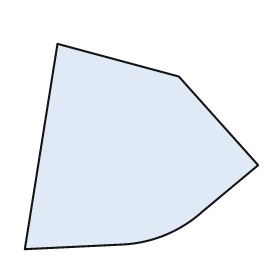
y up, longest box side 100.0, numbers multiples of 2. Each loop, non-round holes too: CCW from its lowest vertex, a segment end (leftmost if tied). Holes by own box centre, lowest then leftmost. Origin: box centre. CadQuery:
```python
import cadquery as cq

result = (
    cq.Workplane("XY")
    .moveTo(-50.0, -44.0)
    .lineTo(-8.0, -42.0)
    .threePointArc((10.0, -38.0), (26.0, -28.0))
    .lineTo(50.0, -8.0)
    .lineTo(16.0, 30.0)
    .lineTo(-36.0, 44.0)
    .close()
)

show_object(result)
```